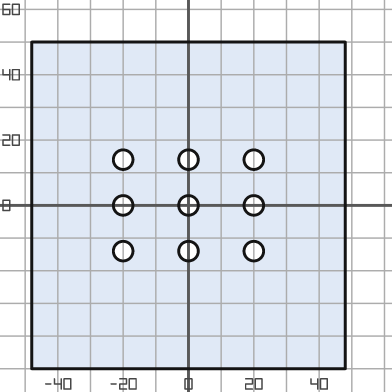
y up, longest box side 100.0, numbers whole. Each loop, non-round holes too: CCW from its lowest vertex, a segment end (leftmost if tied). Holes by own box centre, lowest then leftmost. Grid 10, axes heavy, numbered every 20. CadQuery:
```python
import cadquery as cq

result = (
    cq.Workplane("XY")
    .moveTo(-48.0, -50.0)
    .lineTo(48.0, -50.0)
    .lineTo(48.0, 50.0)
    .lineTo(-48.0, 50.0)
    .close()
    .moveTo(-20.0, -14.0)
    .circle(3.0)
    .moveTo(0.0, -14.0)
    .circle(3.0)
    .moveTo(20.0, -14.0)
    .circle(3.0)
    .moveTo(-20.0, 0.0)
    .circle(3.0)
    .moveTo(0.0, 0.0)
    .circle(3.0)
    .moveTo(20.0, 0.0)
    .circle(3.0)
    .moveTo(-20.0, 14.0)
    .circle(3.0)
    .moveTo(0.0, 14.0)
    .circle(3.0)
    .moveTo(20.0, 14.0)
    .circle(3.0)
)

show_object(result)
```